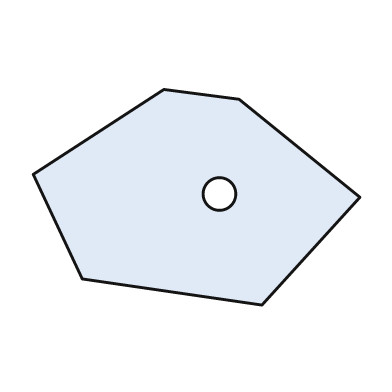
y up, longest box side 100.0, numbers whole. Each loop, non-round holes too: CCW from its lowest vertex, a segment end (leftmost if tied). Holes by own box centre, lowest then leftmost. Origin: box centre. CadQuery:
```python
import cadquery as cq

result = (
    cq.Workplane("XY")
    .moveTo(20.0, -33.0)
    .lineTo(50.0, 0.0)
    .lineTo(13.0, 30.0)
    .lineTo(-10.0, 33.0)
    .lineTo(-50.0, 7.0)
    .lineTo(-35.0, -25.0)
    .close()
    .moveTo(7.0, 1.0)
    .circle(5.0)
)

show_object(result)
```